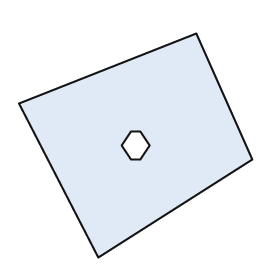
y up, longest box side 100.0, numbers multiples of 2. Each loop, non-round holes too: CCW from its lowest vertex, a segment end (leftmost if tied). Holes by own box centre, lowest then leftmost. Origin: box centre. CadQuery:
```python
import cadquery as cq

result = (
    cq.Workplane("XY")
    .moveTo(-16.0, -48.0)
    .lineTo(50.0, -6.0)
    .lineTo(26.0, 48.0)
    .lineTo(-50.0, 18.0)
    .close()
    .moveTo(-2.0, -6.0)
    .lineTo(2.0, -6.0)
    .lineTo(6.0, 0.0)
    .lineTo(2.0, 6.0)
    .lineTo(-2.0, 6.0)
    .lineTo(-6.0, 0.0)
    .close()
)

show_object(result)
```